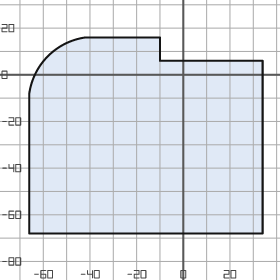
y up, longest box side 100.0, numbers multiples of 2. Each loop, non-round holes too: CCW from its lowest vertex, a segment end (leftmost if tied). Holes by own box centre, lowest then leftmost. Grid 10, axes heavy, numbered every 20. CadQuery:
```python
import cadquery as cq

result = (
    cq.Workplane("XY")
    .moveTo(-66.0, -68.0)
    .lineTo(34.0, -68.0)
    .lineTo(34.0, 6.0)
    .lineTo(-10.0, 6.0)
    .lineTo(-10.0, 16.0)
    .lineTo(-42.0, 16.0)
    .threePointArc((-58.0, 8.0), (-66.0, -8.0))
    .close()
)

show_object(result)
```